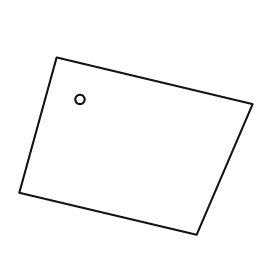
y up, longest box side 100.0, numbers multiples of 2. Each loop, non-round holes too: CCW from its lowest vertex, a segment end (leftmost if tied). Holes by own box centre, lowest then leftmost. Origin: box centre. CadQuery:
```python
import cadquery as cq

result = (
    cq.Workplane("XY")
    .moveTo(26.0, -38.0)
    .lineTo(50.0, 18.0)
    .lineTo(-34.0, 38.0)
    .lineTo(-50.0, -20.0)
    .close()
    .moveTo(-24.0, 20.0)
    .circle(2.0)
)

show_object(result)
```